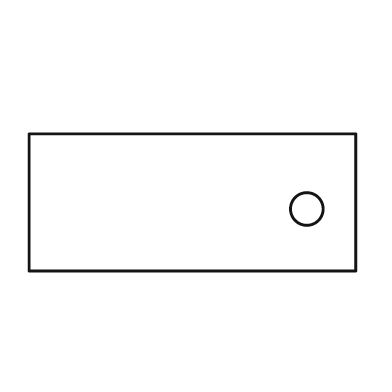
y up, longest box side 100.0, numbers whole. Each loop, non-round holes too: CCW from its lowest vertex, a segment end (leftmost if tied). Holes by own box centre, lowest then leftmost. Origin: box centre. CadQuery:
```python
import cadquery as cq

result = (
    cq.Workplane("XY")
    .moveTo(-50.0, -21.0)
    .lineTo(50.0, -21.0)
    .lineTo(50.0, 21.0)
    .lineTo(-50.0, 21.0)
    .close()
    .moveTo(35.0, -2.0)
    .circle(5.0)
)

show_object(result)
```